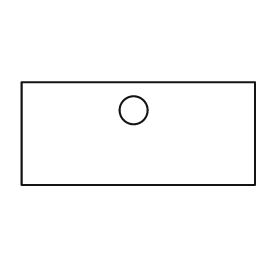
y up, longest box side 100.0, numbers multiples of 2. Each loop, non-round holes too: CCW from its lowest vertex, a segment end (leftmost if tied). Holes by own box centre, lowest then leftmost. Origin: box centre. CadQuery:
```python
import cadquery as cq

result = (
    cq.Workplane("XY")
    .moveTo(-50.0, -22.0)
    .lineTo(50.0, -22.0)
    .lineTo(50.0, 22.0)
    .lineTo(-50.0, 22.0)
    .close()
    .moveTo(-2.0, 10.0)
    .circle(6.0)
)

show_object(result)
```